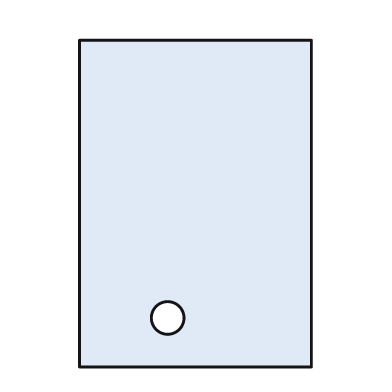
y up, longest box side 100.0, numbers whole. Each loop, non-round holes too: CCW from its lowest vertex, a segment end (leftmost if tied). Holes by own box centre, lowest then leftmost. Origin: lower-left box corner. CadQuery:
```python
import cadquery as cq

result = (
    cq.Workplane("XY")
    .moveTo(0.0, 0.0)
    .lineTo(71.0, 0.0)
    .lineTo(71.0, 100.0)
    .lineTo(0.0, 100.0)
    .close()
    .moveTo(27.0, 15.0)
    .circle(5.0)
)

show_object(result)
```